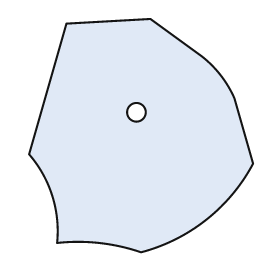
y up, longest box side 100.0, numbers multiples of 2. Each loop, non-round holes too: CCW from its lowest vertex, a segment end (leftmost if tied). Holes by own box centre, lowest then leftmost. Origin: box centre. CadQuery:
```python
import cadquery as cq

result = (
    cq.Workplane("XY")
    .moveTo(0.0, -50.0)
    .threePointArc((28.0, -36.0), (48.0, -12.0))
    .lineTo(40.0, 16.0)
    .threePointArc((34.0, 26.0), (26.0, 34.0))
    .lineTo(4.0, 50.0)
    .lineTo(-32.0, 48.0)
    .lineTo(-48.0, -8.0)
    .threePointArc((-38.0, -26.0), (-36.0, -46.0))
    .threePointArc((-18.0, -46.0), (0.0, -50.0))
    .close()
    .moveTo(-2.0, 10.0)
    .circle(4.0)
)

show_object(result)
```